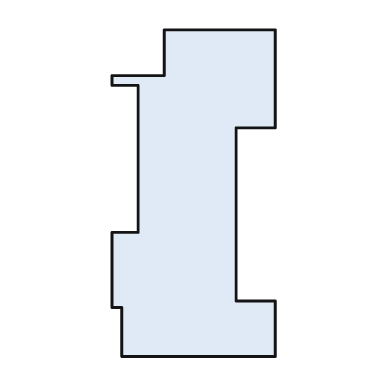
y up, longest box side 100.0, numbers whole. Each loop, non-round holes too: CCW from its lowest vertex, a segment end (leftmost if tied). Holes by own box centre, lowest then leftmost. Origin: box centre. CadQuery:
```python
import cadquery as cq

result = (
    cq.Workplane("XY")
    .moveTo(-22.0, -50.0)
    .lineTo(25.0, -50.0)
    .lineTo(25.0, -33.0)
    .lineTo(13.0, -33.0)
    .lineTo(13.0, 20.0)
    .lineTo(25.0, 20.0)
    .lineTo(25.0, 50.0)
    .lineTo(-9.0, 50.0)
    .lineTo(-9.0, 36.0)
    .lineTo(-25.0, 36.0)
    .lineTo(-25.0, 33.0)
    .lineTo(-17.0, 33.0)
    .lineTo(-17.0, -12.0)
    .lineTo(-25.0, -12.0)
    .lineTo(-25.0, -35.0)
    .lineTo(-22.0, -35.0)
    .close()
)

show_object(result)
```